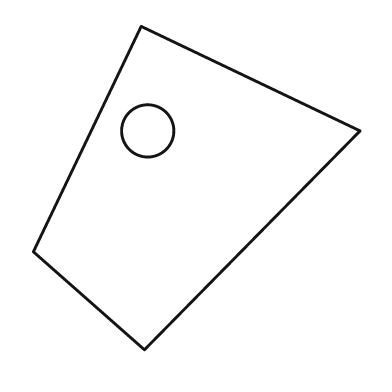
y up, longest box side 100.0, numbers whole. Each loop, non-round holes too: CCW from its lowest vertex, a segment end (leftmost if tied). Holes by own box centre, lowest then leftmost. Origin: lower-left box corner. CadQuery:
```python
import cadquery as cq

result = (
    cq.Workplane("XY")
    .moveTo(34.0, 0.0)
    .lineTo(100.0, 67.0)
    .lineTo(33.0, 99.0)
    .lineTo(0.0, 30.0)
    .close()
    .moveTo(35.0, 67.0)
    .circle(8.0)
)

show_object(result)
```